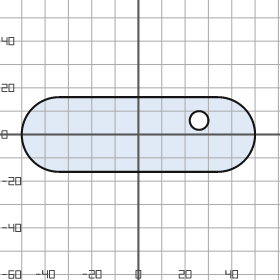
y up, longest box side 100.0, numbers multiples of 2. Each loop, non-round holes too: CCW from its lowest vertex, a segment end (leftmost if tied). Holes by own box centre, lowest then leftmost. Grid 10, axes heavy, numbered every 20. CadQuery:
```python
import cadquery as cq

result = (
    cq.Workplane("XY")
    .moveTo(-34.0, -16.0)
    .lineTo(34.0, -16.0)
    .threePointArc((50.0, 0.0), (34.0, 16.0))
    .lineTo(-34.0, 16.0)
    .threePointArc((-50.0, 0.0), (-34.0, -16.0))
    .close()
    .moveTo(26.0, 6.0)
    .circle(4.0)
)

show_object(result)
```